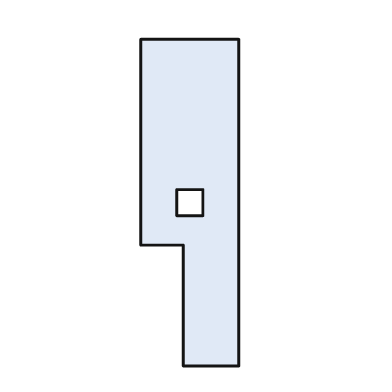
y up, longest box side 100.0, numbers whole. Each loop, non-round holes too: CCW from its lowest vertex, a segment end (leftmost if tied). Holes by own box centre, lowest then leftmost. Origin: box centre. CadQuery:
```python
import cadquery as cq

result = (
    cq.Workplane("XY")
    .moveTo(-2.0, -50.0)
    .lineTo(15.0, -50.0)
    .lineTo(15.0, 50.0)
    .lineTo(-15.0, 50.0)
    .lineTo(-15.0, -13.0)
    .lineTo(-2.0, -13.0)
    .close()
    .moveTo(-4.0, -4.0)
    .lineTo(4.0, -4.0)
    .lineTo(4.0, 4.0)
    .lineTo(-4.0, 4.0)
    .close()
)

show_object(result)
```